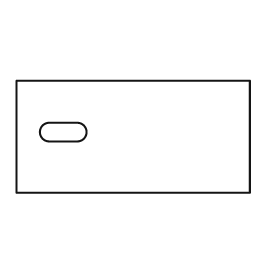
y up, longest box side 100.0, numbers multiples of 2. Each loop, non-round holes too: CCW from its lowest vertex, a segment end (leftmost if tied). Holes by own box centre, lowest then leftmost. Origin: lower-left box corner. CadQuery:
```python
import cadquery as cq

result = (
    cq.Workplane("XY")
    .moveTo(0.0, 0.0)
    .lineTo(100.0, 0.0)
    .lineTo(100.0, 48.0)
    .lineTo(0.0, 48.0)
    .close()
    .moveTo(14.0, 22.0)
    .lineTo(26.0, 22.0)
    .threePointArc((30.0, 26.0), (26.0, 30.0))
    .lineTo(14.0, 30.0)
    .threePointArc((10.0, 26.0), (14.0, 22.0))
    .close()
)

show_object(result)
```